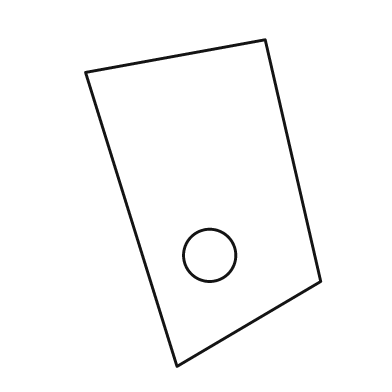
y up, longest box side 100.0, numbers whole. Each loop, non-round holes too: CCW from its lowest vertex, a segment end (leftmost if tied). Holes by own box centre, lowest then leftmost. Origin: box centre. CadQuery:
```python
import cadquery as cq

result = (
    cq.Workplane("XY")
    .moveTo(-8.0, -50.0)
    .lineTo(36.0, -24.0)
    .lineTo(19.0, 50.0)
    .lineTo(-36.0, 40.0)
    .close()
    .moveTo(2.0, -16.0)
    .circle(8.0)
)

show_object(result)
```